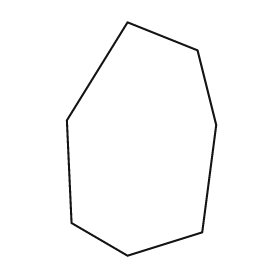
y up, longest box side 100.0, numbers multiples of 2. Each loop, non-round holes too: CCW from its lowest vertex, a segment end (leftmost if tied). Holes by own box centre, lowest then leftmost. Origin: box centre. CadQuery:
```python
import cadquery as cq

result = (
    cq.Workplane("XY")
    .moveTo(-6.0, -50.0)
    .lineTo(26.0, -40.0)
    .lineTo(32.0, 6.0)
    .lineTo(24.0, 38.0)
    .lineTo(-6.0, 50.0)
    .lineTo(-32.0, 8.0)
    .lineTo(-30.0, -36.0)
    .close()
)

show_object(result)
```